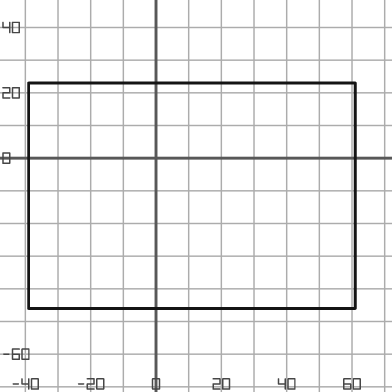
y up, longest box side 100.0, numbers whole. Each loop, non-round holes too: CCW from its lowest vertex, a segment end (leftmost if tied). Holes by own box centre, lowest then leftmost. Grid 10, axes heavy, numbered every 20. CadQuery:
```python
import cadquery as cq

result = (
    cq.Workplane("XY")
    .moveTo(-39.0, -46.0)
    .lineTo(61.0, -46.0)
    .lineTo(61.0, 23.0)
    .lineTo(-39.0, 23.0)
    .close()
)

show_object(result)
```